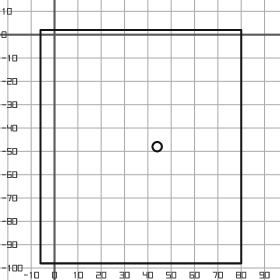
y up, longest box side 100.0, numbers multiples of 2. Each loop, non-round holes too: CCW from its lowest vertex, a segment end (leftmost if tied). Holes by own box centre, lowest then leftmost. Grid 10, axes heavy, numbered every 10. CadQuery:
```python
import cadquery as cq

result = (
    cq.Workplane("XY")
    .moveTo(-6.0, -98.0)
    .lineTo(80.0, -98.0)
    .lineTo(80.0, 2.0)
    .lineTo(-6.0, 2.0)
    .close()
    .moveTo(44.0, -48.0)
    .circle(2.0)
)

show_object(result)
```